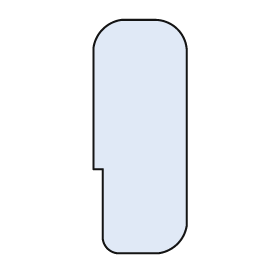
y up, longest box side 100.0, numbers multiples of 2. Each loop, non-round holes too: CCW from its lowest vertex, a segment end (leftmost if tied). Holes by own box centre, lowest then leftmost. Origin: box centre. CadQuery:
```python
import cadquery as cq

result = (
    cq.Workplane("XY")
    .moveTo(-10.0, -50.0)
    .lineTo(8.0, -50.0)
    .threePointArc((16.0, -46.0), (20.0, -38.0))
    .lineTo(20.0, 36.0)
    .threePointArc((16.0, 46.0), (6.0, 50.0))
    .lineTo(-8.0, 50.0)
    .threePointArc((-16.0, 46.0), (-20.0, 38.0))
    .lineTo(-20.0, -14.0)
    .lineTo(-16.0, -14.0)
    .lineTo(-16.0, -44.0)
    .threePointArc((-14.0, -48.0), (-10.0, -50.0))
    .close()
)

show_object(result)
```